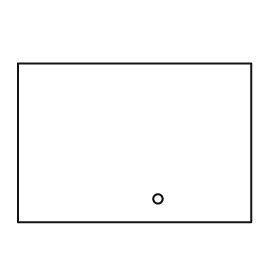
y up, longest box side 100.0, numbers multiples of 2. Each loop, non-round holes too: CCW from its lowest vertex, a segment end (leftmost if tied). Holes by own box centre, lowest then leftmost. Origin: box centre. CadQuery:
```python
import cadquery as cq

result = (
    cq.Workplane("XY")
    .moveTo(-50.0, -34.0)
    .lineTo(50.0, -34.0)
    .lineTo(50.0, 34.0)
    .lineTo(-50.0, 34.0)
    .close()
    .moveTo(10.0, -24.0)
    .circle(2.0)
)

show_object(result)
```